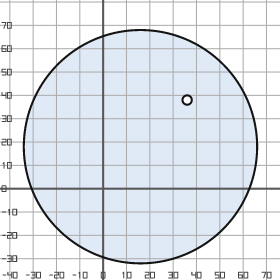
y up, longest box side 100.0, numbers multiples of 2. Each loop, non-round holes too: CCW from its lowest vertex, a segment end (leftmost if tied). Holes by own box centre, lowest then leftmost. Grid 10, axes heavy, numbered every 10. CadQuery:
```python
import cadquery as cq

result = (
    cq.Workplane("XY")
    .moveTo(16.0, 18.0)
    .circle(50.0)
    .moveTo(36.0, 38.0)
    .circle(2.0)
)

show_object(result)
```